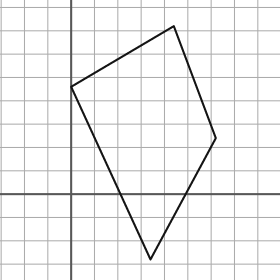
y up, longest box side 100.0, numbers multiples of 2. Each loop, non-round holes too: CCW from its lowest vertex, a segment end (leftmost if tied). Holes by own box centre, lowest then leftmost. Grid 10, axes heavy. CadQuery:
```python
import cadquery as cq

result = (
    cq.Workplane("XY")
    .moveTo(34.0, -28.0)
    .lineTo(62.0, 24.0)
    .lineTo(44.0, 72.0)
    .lineTo(0.0, 46.0)
    .close()
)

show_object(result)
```